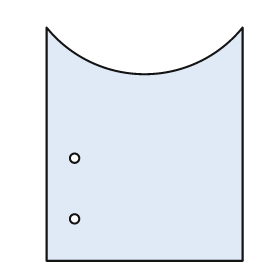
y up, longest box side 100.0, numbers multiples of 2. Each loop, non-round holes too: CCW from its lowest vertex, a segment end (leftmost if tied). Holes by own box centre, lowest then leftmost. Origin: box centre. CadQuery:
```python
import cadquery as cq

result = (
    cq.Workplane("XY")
    .moveTo(-42.0, -50.0)
    .lineTo(42.0, -50.0)
    .lineTo(42.0, 50.0)
    .threePointArc((0.0, 30.0), (-42.0, 50.0))
    .close()
    .moveTo(-30.0, -32.0)
    .circle(2.0)
    .moveTo(-30.0, -6.0)
    .circle(2.0)
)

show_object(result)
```